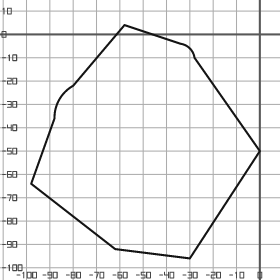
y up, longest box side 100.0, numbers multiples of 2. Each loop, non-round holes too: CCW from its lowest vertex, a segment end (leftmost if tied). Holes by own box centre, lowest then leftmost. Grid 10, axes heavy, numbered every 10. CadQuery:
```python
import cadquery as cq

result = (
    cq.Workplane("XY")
    .moveTo(-30.0, -96.0)
    .lineTo(0.0, -50.0)
    .lineTo(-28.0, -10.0)
    .threePointArc((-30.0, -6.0), (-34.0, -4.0))
    .lineTo(-58.0, 4.0)
    .lineTo(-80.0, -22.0)
    .threePointArc((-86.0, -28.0), (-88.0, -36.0))
    .lineTo(-98.0, -64.0)
    .lineTo(-62.0, -92.0)
    .close()
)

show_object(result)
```